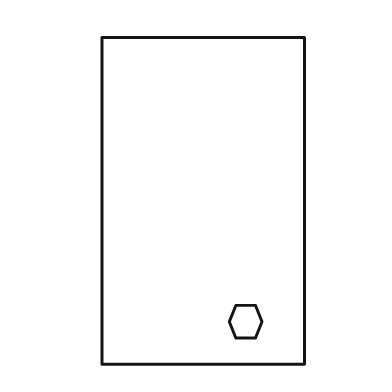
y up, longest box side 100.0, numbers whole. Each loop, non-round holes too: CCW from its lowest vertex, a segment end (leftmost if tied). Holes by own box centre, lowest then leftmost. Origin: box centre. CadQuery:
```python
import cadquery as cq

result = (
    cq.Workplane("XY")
    .moveTo(-31.0, -50.0)
    .lineTo(31.0, -50.0)
    .lineTo(31.0, 50.0)
    .lineTo(-31.0, 50.0)
    .close()
    .moveTo(10.0, -42.0)
    .lineTo(16.0, -42.0)
    .lineTo(18.0, -37.0)
    .lineTo(16.0, -32.0)
    .lineTo(10.0, -32.0)
    .lineTo(8.0, -37.0)
    .close()
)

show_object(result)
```